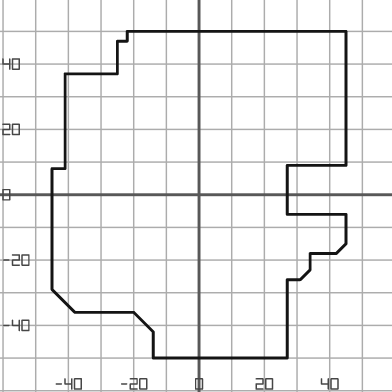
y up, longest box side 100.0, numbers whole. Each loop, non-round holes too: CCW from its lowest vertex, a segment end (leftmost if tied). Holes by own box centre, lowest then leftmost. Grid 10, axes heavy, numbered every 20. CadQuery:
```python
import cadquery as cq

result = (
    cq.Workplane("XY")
    .moveTo(-14.0, -50.0)
    .lineTo(27.0, -50.0)
    .lineTo(27.0, -26.0)
    .lineTo(31.0, -26.0)
    .lineTo(34.0, -23.0)
    .lineTo(34.0, -18.0)
    .lineTo(42.0, -18.0)
    .lineTo(45.0, -15.0)
    .lineTo(45.0, -6.0)
    .lineTo(27.0, -6.0)
    .lineTo(27.0, 9.0)
    .lineTo(45.0, 9.0)
    .lineTo(45.0, 50.0)
    .lineTo(-22.0, 50.0)
    .lineTo(-22.0, 47.0)
    .lineTo(-25.0, 47.0)
    .lineTo(-25.0, 37.0)
    .lineTo(-41.0, 37.0)
    .lineTo(-41.0, 8.0)
    .lineTo(-45.0, 8.0)
    .lineTo(-45.0, -29.0)
    .lineTo(-38.0, -36.0)
    .lineTo(-20.0, -36.0)
    .lineTo(-14.0, -42.0)
    .close()
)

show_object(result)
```